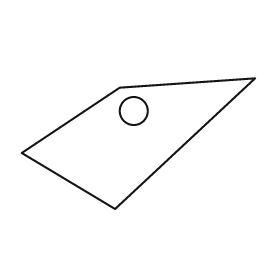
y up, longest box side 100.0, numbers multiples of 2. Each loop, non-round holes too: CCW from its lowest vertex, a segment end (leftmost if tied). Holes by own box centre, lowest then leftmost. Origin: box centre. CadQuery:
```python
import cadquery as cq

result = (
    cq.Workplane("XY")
    .moveTo(-10.0, -28.0)
    .lineTo(50.0, 28.0)
    .lineTo(-8.0, 24.0)
    .lineTo(-50.0, -4.0)
    .close()
    .moveTo(-2.0, 14.0)
    .circle(6.0)
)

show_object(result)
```